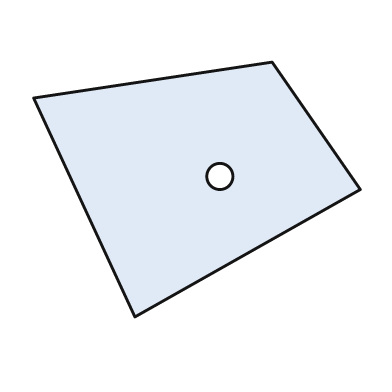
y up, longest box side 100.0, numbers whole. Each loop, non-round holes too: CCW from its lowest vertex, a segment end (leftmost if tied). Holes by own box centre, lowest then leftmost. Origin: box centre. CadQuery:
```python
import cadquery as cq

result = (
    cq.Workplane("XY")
    .moveTo(-19.0, -39.0)
    .lineTo(50.0, 0.0)
    .lineTo(23.0, 39.0)
    .lineTo(-50.0, 28.0)
    .close()
    .moveTo(7.0, 4.0)
    .circle(4.0)
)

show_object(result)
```